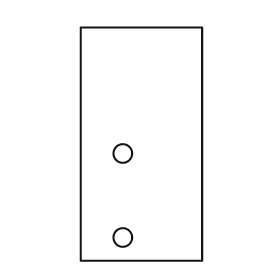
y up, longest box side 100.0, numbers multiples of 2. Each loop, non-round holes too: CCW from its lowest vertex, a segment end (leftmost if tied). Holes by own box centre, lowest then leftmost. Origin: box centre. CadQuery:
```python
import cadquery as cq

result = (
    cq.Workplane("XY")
    .moveTo(-26.0, -50.0)
    .lineTo(26.0, -50.0)
    .lineTo(26.0, 50.0)
    .lineTo(-26.0, 50.0)
    .close()
    .moveTo(-8.0, -40.0)
    .circle(4.0)
    .moveTo(-8.0, -4.0)
    .circle(4.0)
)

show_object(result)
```